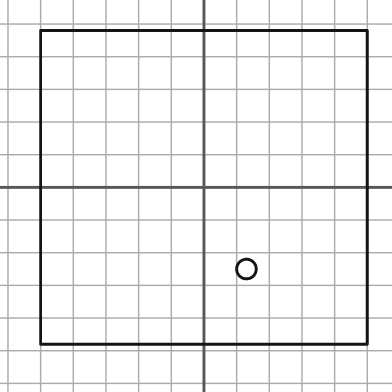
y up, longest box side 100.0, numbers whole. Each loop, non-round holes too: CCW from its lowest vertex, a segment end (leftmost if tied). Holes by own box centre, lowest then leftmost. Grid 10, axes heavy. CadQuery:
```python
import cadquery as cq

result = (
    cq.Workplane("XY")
    .moveTo(-50.0, -48.0)
    .lineTo(50.0, -48.0)
    .lineTo(50.0, 48.0)
    .lineTo(-50.0, 48.0)
    .close()
    .moveTo(13.0, -25.0)
    .circle(3.0)
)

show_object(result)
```